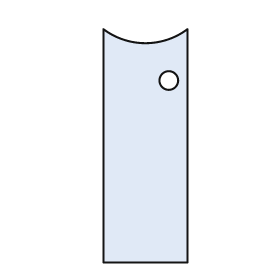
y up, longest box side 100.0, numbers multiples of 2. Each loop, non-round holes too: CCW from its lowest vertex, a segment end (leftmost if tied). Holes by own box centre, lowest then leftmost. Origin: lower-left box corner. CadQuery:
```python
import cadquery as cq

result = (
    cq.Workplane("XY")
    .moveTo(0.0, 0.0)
    .lineTo(36.0, 0.0)
    .lineTo(36.0, 100.0)
    .threePointArc((18.0, 94.0), (0.0, 100.0))
    .close()
    .moveTo(28.0, 78.0)
    .circle(4.0)
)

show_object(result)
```